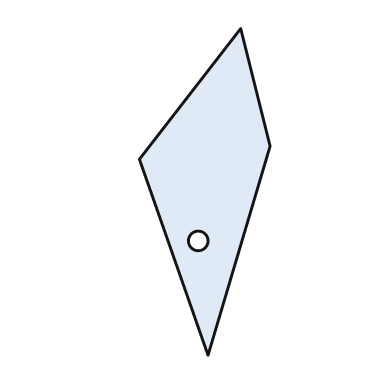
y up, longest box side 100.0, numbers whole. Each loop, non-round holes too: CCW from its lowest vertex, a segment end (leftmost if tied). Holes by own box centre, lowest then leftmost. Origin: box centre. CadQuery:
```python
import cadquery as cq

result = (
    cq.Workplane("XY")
    .moveTo(1.0, -50.0)
    .lineTo(20.0, 14.0)
    .lineTo(11.0, 50.0)
    .lineTo(-20.0, 10.0)
    .close()
    .moveTo(-2.0, -15.0)
    .circle(3.0)
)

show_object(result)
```